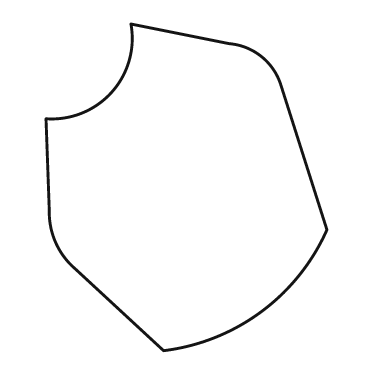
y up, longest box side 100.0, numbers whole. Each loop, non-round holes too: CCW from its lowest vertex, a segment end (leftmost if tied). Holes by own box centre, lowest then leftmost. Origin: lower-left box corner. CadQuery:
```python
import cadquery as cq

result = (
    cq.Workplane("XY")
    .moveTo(36.0, 0.0)
    .threePointArc((66.0, 12.0), (86.0, 37.0))
    .lineTo(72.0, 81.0)
    .threePointArc((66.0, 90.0), (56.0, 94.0))
    .lineTo(26.0, 100.0)
    .threePointArc((20.0, 79.0), (0.0, 71.0))
    .lineTo(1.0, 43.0)
    .threePointArc((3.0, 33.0), (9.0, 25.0))
    .close()
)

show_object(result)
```